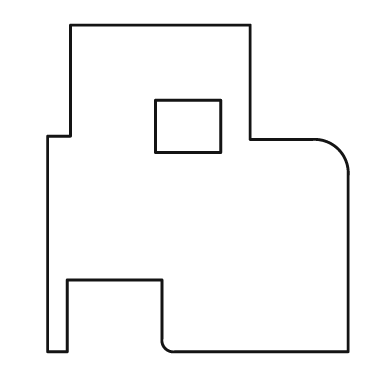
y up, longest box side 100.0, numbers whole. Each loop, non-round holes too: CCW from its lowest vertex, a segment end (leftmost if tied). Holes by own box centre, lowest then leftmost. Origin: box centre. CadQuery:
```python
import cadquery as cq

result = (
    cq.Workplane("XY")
    .moveTo(-46.0, -50.0)
    .lineTo(-40.0, -50.0)
    .lineTo(-40.0, -28.0)
    .lineTo(-11.0, -28.0)
    .lineTo(-11.0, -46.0)
    .threePointArc((-10.0, -49.0), (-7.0, -50.0))
    .lineTo(46.0, -50.0)
    .lineTo(46.0, 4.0)
    .threePointArc((43.0, 12.0), (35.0, 15.0))
    .lineTo(16.0, 15.0)
    .lineTo(16.0, 50.0)
    .lineTo(-39.0, 50.0)
    .lineTo(-39.0, 16.0)
    .lineTo(-46.0, 16.0)
    .close()
    .moveTo(-13.0, 11.0)
    .lineTo(7.0, 11.0)
    .lineTo(7.0, 27.0)
    .lineTo(-13.0, 27.0)
    .close()
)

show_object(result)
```